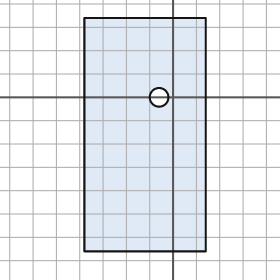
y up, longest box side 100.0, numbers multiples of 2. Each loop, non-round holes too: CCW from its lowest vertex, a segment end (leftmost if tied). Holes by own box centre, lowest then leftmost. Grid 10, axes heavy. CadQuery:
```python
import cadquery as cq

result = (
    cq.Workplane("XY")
    .moveTo(-38.0, -66.0)
    .lineTo(14.0, -66.0)
    .lineTo(14.0, 34.0)
    .lineTo(-38.0, 34.0)
    .close()
    .moveTo(-6.0, 0.0)
    .circle(4.0)
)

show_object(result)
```